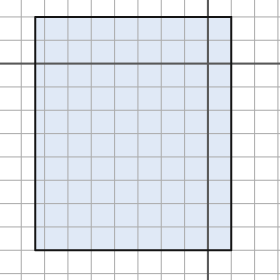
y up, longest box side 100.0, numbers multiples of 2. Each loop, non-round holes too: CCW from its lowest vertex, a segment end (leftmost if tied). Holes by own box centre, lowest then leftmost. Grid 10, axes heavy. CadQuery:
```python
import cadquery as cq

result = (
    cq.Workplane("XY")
    .moveTo(-74.0, -80.0)
    .lineTo(10.0, -80.0)
    .lineTo(10.0, 20.0)
    .lineTo(-74.0, 20.0)
    .close()
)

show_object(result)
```